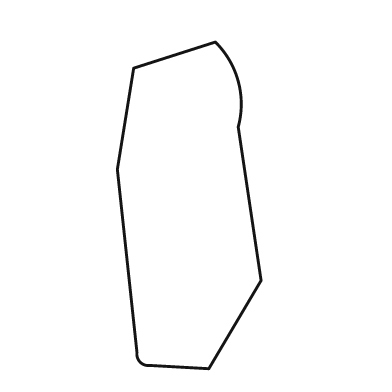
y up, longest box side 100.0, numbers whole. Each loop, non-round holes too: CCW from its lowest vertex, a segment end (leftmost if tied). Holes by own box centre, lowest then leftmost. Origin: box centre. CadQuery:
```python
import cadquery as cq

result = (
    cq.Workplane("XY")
    .moveTo(6.0, -50.0)
    .lineTo(22.0, -23.0)
    .lineTo(15.0, 24.0)
    .threePointArc((15.0, 38.0), (8.0, 50.0))
    .lineTo(-17.0, 42.0)
    .lineTo(-22.0, 11.0)
    .lineTo(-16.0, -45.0)
    .threePointArc((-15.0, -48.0), (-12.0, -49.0))
    .close()
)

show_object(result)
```